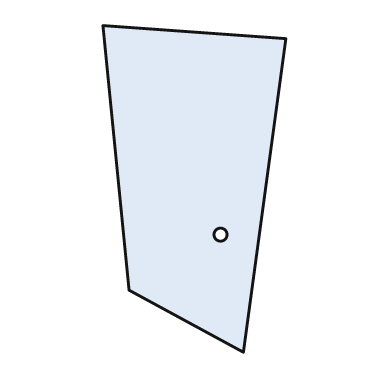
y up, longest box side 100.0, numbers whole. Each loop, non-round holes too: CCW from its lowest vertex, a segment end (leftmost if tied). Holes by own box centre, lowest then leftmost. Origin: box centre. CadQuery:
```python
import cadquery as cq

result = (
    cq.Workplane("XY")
    .moveTo(15.0, -50.0)
    .lineTo(28.0, 46.0)
    .lineTo(-28.0, 50.0)
    .lineTo(-20.0, -31.0)
    .close()
    .moveTo(8.0, -14.0)
    .circle(2.0)
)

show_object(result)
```